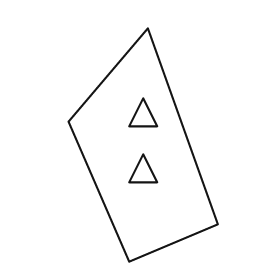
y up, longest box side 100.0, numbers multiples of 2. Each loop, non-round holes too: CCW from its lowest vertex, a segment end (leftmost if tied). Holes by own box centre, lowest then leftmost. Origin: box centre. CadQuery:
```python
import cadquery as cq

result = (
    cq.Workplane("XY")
    .moveTo(-6.0, -50.0)
    .lineTo(32.0, -34.0)
    .lineTo(2.0, 50.0)
    .lineTo(-32.0, 10.0)
    .close()
    .moveTo(-6.0, -16.0)
    .lineTo(6.0, -16.0)
    .lineTo(0.0, -4.0)
    .close()
    .moveTo(-6.0, 8.0)
    .lineTo(6.0, 8.0)
    .lineTo(0.0, 20.0)
    .close()
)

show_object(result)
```